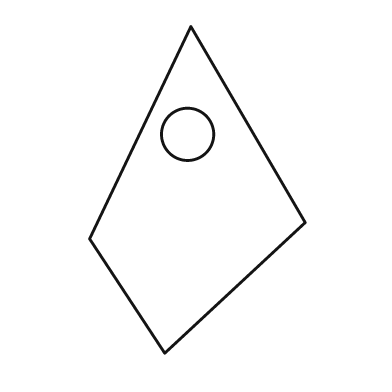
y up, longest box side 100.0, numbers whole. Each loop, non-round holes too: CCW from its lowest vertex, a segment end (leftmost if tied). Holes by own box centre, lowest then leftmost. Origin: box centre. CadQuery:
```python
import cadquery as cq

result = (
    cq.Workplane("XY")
    .moveTo(-10.0, -50.0)
    .lineTo(33.0, -10.0)
    .lineTo(-2.0, 50.0)
    .lineTo(-33.0, -15.0)
    .close()
    .moveTo(-3.0, 17.0)
    .circle(8.0)
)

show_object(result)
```